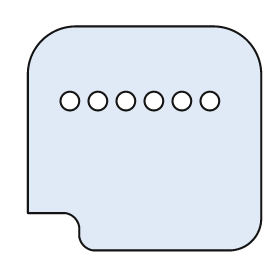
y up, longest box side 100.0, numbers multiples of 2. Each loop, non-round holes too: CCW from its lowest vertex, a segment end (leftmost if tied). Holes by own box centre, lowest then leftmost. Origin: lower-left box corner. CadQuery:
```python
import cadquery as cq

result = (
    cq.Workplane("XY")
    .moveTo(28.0, 0.0)
    .lineTo(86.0, 0.0)
    .threePointArc((96.0, 4.0), (100.0, 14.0))
    .lineTo(100.0, 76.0)
    .threePointArc((94.0, 90.0), (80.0, 96.0))
    .lineTo(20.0, 96.0)
    .threePointArc((6.0, 90.0), (0.0, 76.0))
    .lineTo(0.0, 16.0)
    .lineTo(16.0, 16.0)
    .threePointArc((20.0, 14.0), (22.0, 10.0))
    .lineTo(22.0, 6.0)
    .threePointArc((24.0, 2.0), (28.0, 0.0))
    .close()
    .moveTo(18.0, 64.0)
    .circle(4.0)
    .moveTo(30.0, 64.0)
    .circle(4.0)
    .moveTo(42.0, 64.0)
    .circle(4.0)
    .moveTo(54.0, 64.0)
    .circle(4.0)
    .moveTo(66.0, 64.0)
    .circle(4.0)
    .moveTo(78.0, 64.0)
    .circle(4.0)
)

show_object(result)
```